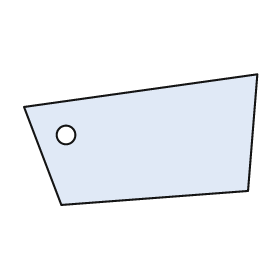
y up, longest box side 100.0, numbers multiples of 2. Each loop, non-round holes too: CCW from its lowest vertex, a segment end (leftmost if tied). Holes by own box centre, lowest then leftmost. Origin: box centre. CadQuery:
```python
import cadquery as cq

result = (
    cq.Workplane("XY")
    .moveTo(-34.0, -28.0)
    .lineTo(46.0, -22.0)
    .lineTo(50.0, 28.0)
    .lineTo(-50.0, 14.0)
    .close()
    .moveTo(-32.0, 2.0)
    .circle(4.0)
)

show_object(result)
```